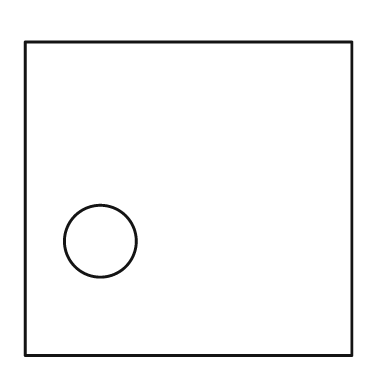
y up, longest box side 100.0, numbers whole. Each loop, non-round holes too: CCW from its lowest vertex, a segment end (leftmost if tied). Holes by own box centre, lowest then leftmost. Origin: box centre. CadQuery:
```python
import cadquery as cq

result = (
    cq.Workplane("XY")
    .moveTo(-50.0, -48.0)
    .lineTo(50.0, -48.0)
    .lineTo(50.0, 48.0)
    .lineTo(-50.0, 48.0)
    .close()
    .moveTo(-27.0, -13.0)
    .circle(11.0)
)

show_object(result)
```